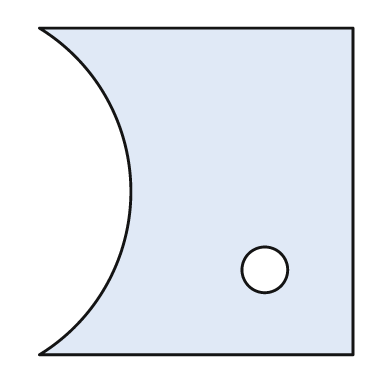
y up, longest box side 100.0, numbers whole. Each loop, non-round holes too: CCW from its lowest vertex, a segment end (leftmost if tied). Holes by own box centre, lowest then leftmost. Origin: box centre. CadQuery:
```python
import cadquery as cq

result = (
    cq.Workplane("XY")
    .moveTo(-48.0, -50.0)
    .lineTo(48.0, -50.0)
    .lineTo(48.0, 50.0)
    .lineTo(-48.0, 50.0)
    .threePointArc((-20.0, 0.0), (-48.0, -50.0))
    .close()
    .moveTo(21.0, -24.0)
    .circle(7.0)
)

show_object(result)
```